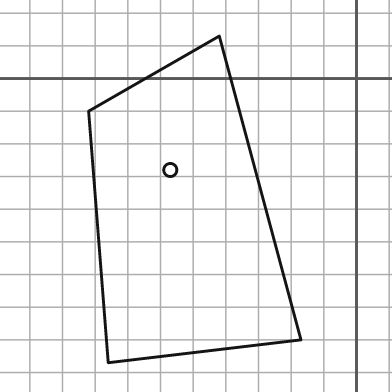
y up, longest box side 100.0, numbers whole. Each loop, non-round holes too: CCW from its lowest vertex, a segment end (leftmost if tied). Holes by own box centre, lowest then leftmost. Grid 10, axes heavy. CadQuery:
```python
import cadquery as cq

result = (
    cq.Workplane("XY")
    .moveTo(-76.0, -87.0)
    .lineTo(-17.0, -80.0)
    .lineTo(-42.0, 13.0)
    .lineTo(-82.0, -10.0)
    .close()
    .moveTo(-57.0, -28.0)
    .circle(2.0)
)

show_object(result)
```